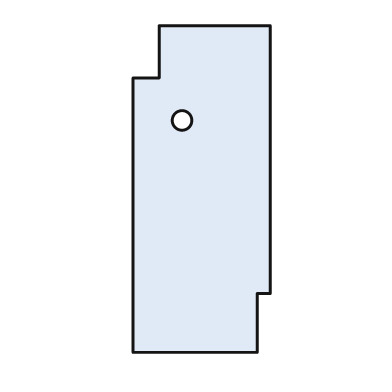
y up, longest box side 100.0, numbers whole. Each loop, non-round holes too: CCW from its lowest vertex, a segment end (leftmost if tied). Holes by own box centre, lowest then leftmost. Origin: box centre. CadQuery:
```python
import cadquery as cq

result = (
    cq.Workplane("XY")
    .moveTo(-21.0, -50.0)
    .lineTo(17.0, -50.0)
    .lineTo(17.0, -32.0)
    .lineTo(21.0, -32.0)
    .lineTo(21.0, 50.0)
    .lineTo(-13.0, 50.0)
    .lineTo(-13.0, 34.0)
    .lineTo(-21.0, 34.0)
    .close()
    .moveTo(-6.0, 21.0)
    .circle(3.0)
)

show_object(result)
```